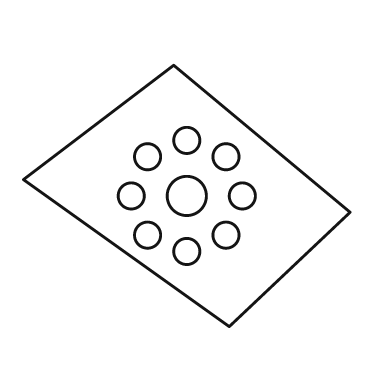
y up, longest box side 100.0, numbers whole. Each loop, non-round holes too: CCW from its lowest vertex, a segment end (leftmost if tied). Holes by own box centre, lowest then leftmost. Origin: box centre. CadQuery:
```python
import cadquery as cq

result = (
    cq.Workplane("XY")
    .moveTo(13.0, -40.0)
    .lineTo(50.0, -5.0)
    .lineTo(-4.0, 40.0)
    .lineTo(-50.0, 5.0)
    .close()
    .moveTo(0.0, -17.0)
    .circle(4.0)
    .moveTo(-12.0, -12.0)
    .circle(4.0)
    .moveTo(12.0, -12.0)
    .circle(4.0)
    .moveTo(-17.0, 0.0)
    .circle(4.0)
    .moveTo(0.0, 0.0)
    .circle(6.0)
    .moveTo(17.0, 0.0)
    .circle(4.0)
    .moveTo(-12.0, 12.0)
    .circle(4.0)
    .moveTo(12.0, 12.0)
    .circle(4.0)
    .moveTo(0.0, 17.0)
    .circle(4.0)
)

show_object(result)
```